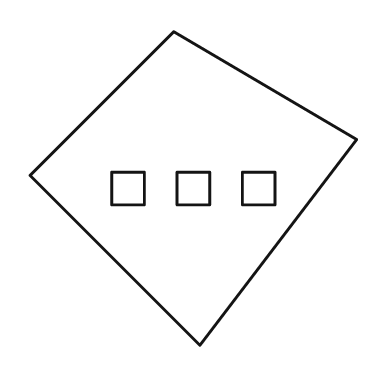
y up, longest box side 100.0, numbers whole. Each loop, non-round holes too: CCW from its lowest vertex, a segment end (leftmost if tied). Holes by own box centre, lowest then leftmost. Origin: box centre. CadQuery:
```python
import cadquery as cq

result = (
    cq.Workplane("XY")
    .moveTo(2.0, -48.0)
    .lineTo(50.0, 15.0)
    .lineTo(-6.0, 48.0)
    .lineTo(-50.0, 4.0)
    .close()
    .moveTo(-25.0, -5.0)
    .lineTo(-15.0, -5.0)
    .lineTo(-15.0, 5.0)
    .lineTo(-25.0, 5.0)
    .close()
    .moveTo(-5.0, -5.0)
    .lineTo(5.0, -5.0)
    .lineTo(5.0, 5.0)
    .lineTo(-5.0, 5.0)
    .close()
    .moveTo(15.0, -5.0)
    .lineTo(25.0, -5.0)
    .lineTo(25.0, 5.0)
    .lineTo(15.0, 5.0)
    .close()
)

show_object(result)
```